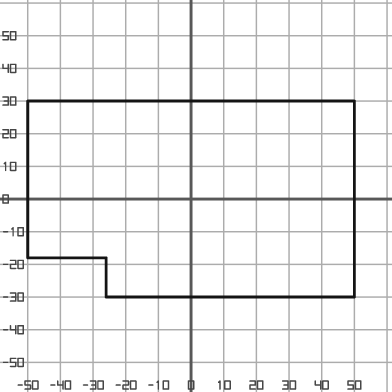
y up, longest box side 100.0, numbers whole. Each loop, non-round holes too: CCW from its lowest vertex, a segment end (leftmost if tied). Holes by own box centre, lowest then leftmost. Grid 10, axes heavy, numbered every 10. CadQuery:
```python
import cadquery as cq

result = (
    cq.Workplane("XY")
    .moveTo(-26.0, -30.0)
    .lineTo(50.0, -30.0)
    .lineTo(50.0, 30.0)
    .lineTo(-50.0, 30.0)
    .lineTo(-50.0, -18.0)
    .lineTo(-26.0, -18.0)
    .close()
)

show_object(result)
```